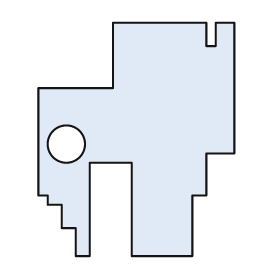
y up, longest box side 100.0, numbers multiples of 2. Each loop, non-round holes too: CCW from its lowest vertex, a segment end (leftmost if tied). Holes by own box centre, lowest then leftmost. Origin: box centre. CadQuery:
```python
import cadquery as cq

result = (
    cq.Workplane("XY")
    .moveTo(-26.0, -50.0)
    .lineTo(-20.0, -50.0)
    .lineTo(-20.0, -10.0)
    .lineTo(-2.0, -10.0)
    .lineTo(-2.0, -50.0)
    .lineTo(24.0, -50.0)
    .lineTo(24.0, -24.0)
    .lineTo(30.0, -24.0)
    .lineTo(30.0, -6.0)
    .lineTo(42.0, -6.0)
    .lineTo(42.0, 50.0)
    .lineTo(34.0, 50.0)
    .lineTo(34.0, 40.0)
    .lineTo(30.0, 40.0)
    .lineTo(30.0, 50.0)
    .lineTo(-10.0, 50.0)
    .lineTo(-10.0, 22.0)
    .lineTo(-42.0, 22.0)
    .lineTo(-42.0, -24.0)
    .lineTo(-38.0, -24.0)
    .lineTo(-38.0, -28.0)
    .lineTo(-32.0, -28.0)
    .lineTo(-32.0, -38.0)
    .lineTo(-26.0, -38.0)
    .close()
    .moveTo(-30.0, -2.0)
    .circle(8.0)
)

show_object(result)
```